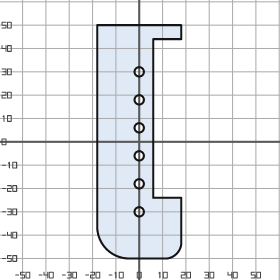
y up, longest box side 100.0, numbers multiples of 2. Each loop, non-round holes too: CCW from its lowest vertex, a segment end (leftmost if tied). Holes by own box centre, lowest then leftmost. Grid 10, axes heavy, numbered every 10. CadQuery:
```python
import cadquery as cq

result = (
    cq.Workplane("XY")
    .moveTo(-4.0, -50.0)
    .lineTo(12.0, -50.0)
    .threePointArc((16.0, -48.0), (18.0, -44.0))
    .lineTo(18.0, -24.0)
    .lineTo(6.0, -24.0)
    .lineTo(6.0, 44.0)
    .lineTo(18.0, 44.0)
    .lineTo(18.0, 50.0)
    .lineTo(-18.0, 50.0)
    .lineTo(-18.0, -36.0)
    .threePointArc((-14.0, -46.0), (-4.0, -50.0))
    .close()
    .moveTo(0.0, -30.0)
    .circle(2.0)
    .moveTo(0.0, -18.0)
    .circle(2.0)
    .moveTo(0.0, -6.0)
    .circle(2.0)
    .moveTo(0.0, 6.0)
    .circle(2.0)
    .moveTo(0.0, 18.0)
    .circle(2.0)
    .moveTo(0.0, 30.0)
    .circle(2.0)
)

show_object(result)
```